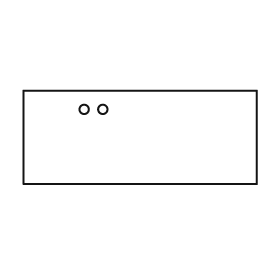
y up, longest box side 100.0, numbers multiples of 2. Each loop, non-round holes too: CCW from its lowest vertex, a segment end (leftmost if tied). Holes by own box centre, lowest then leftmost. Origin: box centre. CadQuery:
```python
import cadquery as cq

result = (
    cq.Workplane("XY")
    .moveTo(-50.0, -20.0)
    .lineTo(50.0, -20.0)
    .lineTo(50.0, 20.0)
    .lineTo(-50.0, 20.0)
    .close()
    .moveTo(-24.0, 12.0)
    .circle(2.0)
    .moveTo(-16.0, 12.0)
    .circle(2.0)
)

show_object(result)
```